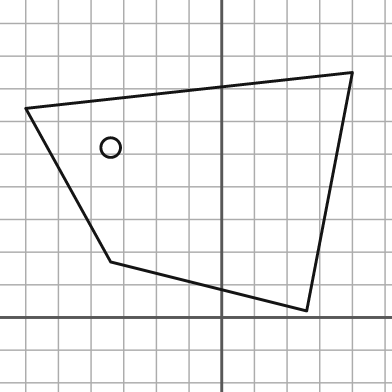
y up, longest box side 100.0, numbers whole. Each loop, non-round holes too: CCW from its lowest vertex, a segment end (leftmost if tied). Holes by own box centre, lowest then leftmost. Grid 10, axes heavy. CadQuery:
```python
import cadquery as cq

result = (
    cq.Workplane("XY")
    .moveTo(26.0, 2.0)
    .lineTo(40.0, 75.0)
    .lineTo(-60.0, 64.0)
    .lineTo(-34.0, 17.0)
    .close()
    .moveTo(-34.0, 52.0)
    .circle(3.0)
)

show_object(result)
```